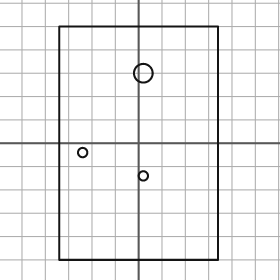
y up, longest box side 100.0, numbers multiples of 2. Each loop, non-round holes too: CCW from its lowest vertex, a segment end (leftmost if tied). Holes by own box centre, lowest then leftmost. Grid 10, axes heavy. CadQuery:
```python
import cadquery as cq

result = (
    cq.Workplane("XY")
    .moveTo(-34.0, -50.0)
    .lineTo(34.0, -50.0)
    .lineTo(34.0, 50.0)
    .lineTo(-34.0, 50.0)
    .close()
    .moveTo(2.0, -14.0)
    .circle(2.0)
    .moveTo(-24.0, -4.0)
    .circle(2.0)
    .moveTo(2.0, 30.0)
    .circle(4.0)
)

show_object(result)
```